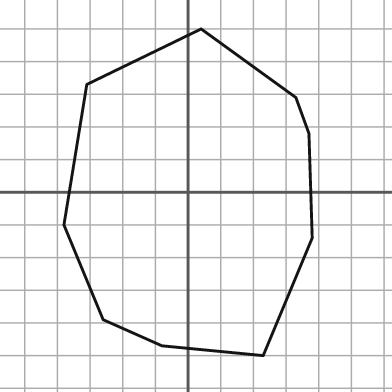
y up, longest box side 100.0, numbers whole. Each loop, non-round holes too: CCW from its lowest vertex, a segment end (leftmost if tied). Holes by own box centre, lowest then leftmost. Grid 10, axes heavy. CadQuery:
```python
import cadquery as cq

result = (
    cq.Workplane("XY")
    .moveTo(23.0, -50.0)
    .lineTo(38.0, -14.0)
    .lineTo(37.0, 18.0)
    .lineTo(33.0, 29.0)
    .lineTo(4.0, 50.0)
    .lineTo(-31.0, 33.0)
    .lineTo(-38.0, -10.0)
    .lineTo(-26.0, -39.0)
    .lineTo(-8.0, -47.0)
    .close()
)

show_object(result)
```